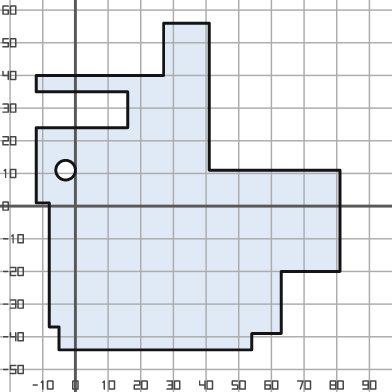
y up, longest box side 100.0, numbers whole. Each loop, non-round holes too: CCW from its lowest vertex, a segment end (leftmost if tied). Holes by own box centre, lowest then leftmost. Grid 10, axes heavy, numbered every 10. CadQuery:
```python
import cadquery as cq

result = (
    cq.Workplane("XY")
    .moveTo(-5.0, -44.0)
    .lineTo(54.0, -44.0)
    .lineTo(54.0, -39.0)
    .lineTo(63.0, -39.0)
    .lineTo(63.0, -20.0)
    .lineTo(81.0, -20.0)
    .lineTo(81.0, 11.0)
    .lineTo(41.0, 11.0)
    .lineTo(41.0, 56.0)
    .lineTo(27.0, 56.0)
    .lineTo(27.0, 40.0)
    .lineTo(-12.0, 40.0)
    .lineTo(-12.0, 35.0)
    .lineTo(16.0, 35.0)
    .lineTo(16.0, 24.0)
    .lineTo(-12.0, 24.0)
    .lineTo(-12.0, 1.0)
    .lineTo(-8.0, 1.0)
    .lineTo(-8.0, -37.0)
    .lineTo(-5.0, -37.0)
    .close()
    .moveTo(-3.0, 11.0)
    .circle(3.0)
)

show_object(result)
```